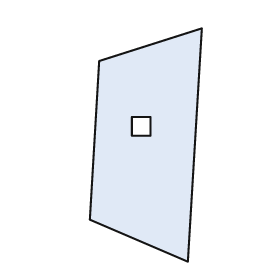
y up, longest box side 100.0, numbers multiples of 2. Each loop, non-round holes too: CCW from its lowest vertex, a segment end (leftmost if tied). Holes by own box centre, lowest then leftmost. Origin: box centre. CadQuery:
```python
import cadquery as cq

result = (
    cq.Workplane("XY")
    .moveTo(18.0, -50.0)
    .lineTo(24.0, 50.0)
    .lineTo(-20.0, 36.0)
    .lineTo(-24.0, -32.0)
    .close()
    .moveTo(-6.0, 4.0)
    .lineTo(2.0, 4.0)
    .lineTo(2.0, 12.0)
    .lineTo(-6.0, 12.0)
    .close()
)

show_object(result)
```